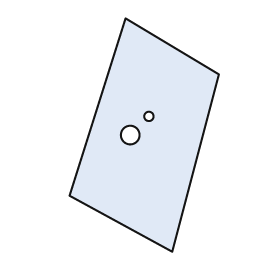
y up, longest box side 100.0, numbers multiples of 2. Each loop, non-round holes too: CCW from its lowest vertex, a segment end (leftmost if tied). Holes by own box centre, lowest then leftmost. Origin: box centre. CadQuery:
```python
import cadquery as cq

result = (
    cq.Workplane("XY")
    .moveTo(12.0, -50.0)
    .lineTo(32.0, 26.0)
    .lineTo(-8.0, 50.0)
    .lineTo(-32.0, -26.0)
    .close()
    .moveTo(-6.0, 0.0)
    .circle(4.0)
    .moveTo(2.0, 8.0)
    .circle(2.0)
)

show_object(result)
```